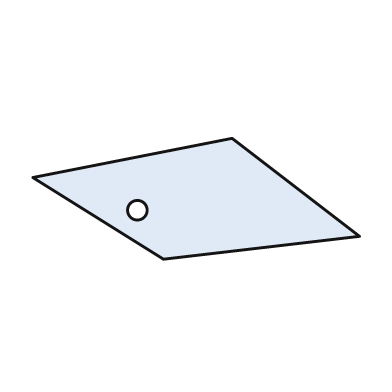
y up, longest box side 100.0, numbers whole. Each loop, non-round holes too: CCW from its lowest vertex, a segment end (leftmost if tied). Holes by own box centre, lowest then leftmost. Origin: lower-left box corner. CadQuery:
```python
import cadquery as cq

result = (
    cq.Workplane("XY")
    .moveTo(40.0, 0.0)
    .lineTo(100.0, 7.0)
    .lineTo(61.0, 37.0)
    .lineTo(0.0, 25.0)
    .close()
    .moveTo(32.0, 15.0)
    .circle(3.0)
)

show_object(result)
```